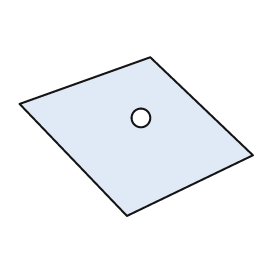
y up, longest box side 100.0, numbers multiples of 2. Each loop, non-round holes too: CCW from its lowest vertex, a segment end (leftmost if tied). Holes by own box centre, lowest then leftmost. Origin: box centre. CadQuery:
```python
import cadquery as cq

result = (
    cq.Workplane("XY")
    .moveTo(-4.0, -34.0)
    .lineTo(50.0, -8.0)
    .lineTo(6.0, 34.0)
    .lineTo(-50.0, 14.0)
    .close()
    .moveTo(2.0, 8.0)
    .circle(4.0)
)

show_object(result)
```